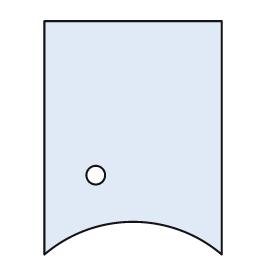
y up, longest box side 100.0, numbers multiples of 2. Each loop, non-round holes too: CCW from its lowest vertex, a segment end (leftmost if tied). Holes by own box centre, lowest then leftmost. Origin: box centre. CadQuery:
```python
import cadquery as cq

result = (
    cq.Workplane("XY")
    .moveTo(-38.0, -50.0)
    .threePointArc((0.0, -36.0), (38.0, -50.0))
    .lineTo(38.0, 50.0)
    .lineTo(-38.0, 50.0)
    .close()
    .moveTo(-16.0, -16.0)
    .circle(4.0)
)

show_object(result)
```